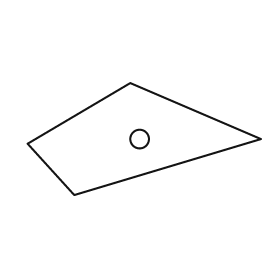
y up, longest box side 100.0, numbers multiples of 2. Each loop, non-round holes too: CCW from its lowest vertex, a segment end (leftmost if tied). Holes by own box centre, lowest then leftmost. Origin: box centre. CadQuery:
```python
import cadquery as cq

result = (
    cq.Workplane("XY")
    .moveTo(-30.0, -24.0)
    .lineTo(50.0, 0.0)
    .lineTo(-6.0, 24.0)
    .lineTo(-50.0, -2.0)
    .close()
    .moveTo(-2.0, 0.0)
    .circle(4.0)
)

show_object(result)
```